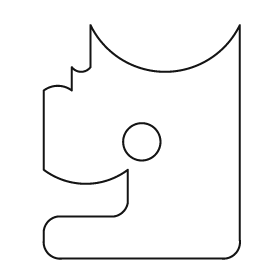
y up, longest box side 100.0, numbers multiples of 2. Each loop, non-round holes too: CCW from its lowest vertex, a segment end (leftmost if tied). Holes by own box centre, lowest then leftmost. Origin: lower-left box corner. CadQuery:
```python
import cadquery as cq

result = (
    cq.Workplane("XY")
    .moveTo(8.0, 0.0)
    .lineTo(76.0, 0.0)
    .threePointArc((82.0, 2.0), (84.0, 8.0))
    .lineTo(84.0, 100.0)
    .threePointArc((52.0, 80.0), (20.0, 100.0))
    .lineTo(20.0, 82.0)
    .threePointArc((16.0, 80.0), (12.0, 82.0))
    .lineTo(12.0, 72.0)
    .threePointArc((6.0, 74.0), (0.0, 72.0))
    .lineTo(0.0, 38.0)
    .threePointArc((18.0, 32.0), (36.0, 38.0))
    .lineTo(36.0, 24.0)
    .threePointArc((34.0, 20.0), (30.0, 18.0))
    .lineTo(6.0, 18.0)
    .threePointArc((2.0, 16.0), (0.0, 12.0))
    .lineTo(0.0, 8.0)
    .threePointArc((2.0, 2.0), (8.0, 0.0))
    .close()
    .moveTo(42.0, 50.0)
    .circle(8.0)
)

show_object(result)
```